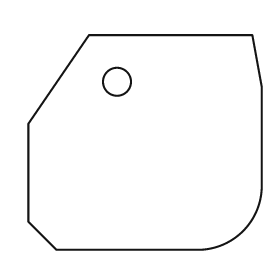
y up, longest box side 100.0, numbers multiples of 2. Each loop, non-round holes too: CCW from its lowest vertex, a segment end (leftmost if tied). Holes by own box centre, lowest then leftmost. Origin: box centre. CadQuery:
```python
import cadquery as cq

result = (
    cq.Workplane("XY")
    .moveTo(-38.0, -46.0)
    .lineTo(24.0, -46.0)
    .threePointArc((42.0, -38.0), (50.0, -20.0))
    .lineTo(50.0, 24.0)
    .lineTo(46.0, 46.0)
    .lineTo(-24.0, 46.0)
    .lineTo(-50.0, 8.0)
    .lineTo(-50.0, -34.0)
    .close()
    .moveTo(-12.0, 26.0)
    .circle(6.0)
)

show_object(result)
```